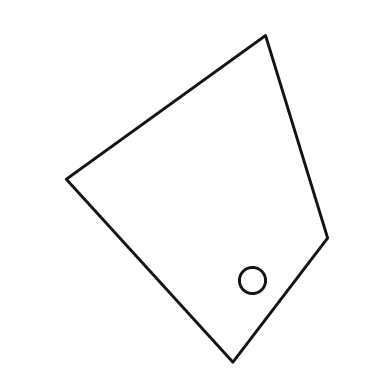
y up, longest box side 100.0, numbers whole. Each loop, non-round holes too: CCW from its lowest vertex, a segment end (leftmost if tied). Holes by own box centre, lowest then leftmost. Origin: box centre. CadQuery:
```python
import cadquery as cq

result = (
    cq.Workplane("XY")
    .moveTo(11.0, -50.0)
    .lineTo(40.0, -12.0)
    .lineTo(21.0, 50.0)
    .lineTo(-40.0, 6.0)
    .close()
    .moveTo(17.0, -25.0)
    .circle(4.0)
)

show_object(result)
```